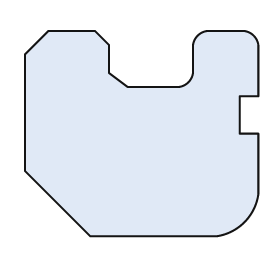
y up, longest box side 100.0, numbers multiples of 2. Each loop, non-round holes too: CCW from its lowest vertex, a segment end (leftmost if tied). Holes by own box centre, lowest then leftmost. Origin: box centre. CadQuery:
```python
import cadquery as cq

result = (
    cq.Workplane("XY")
    .moveTo(-22.0, -44.0)
    .lineTo(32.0, -44.0)
    .threePointArc((44.0, -38.0), (50.0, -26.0))
    .lineTo(50.0, 0.0)
    .lineTo(42.0, 0.0)
    .lineTo(42.0, 16.0)
    .lineTo(50.0, 16.0)
    .lineTo(50.0, 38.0)
    .threePointArc((48.0, 42.0), (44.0, 44.0))
    .lineTo(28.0, 44.0)
    .threePointArc((24.0, 42.0), (22.0, 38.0))
    .lineTo(22.0, 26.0)
    .threePointArc((20.0, 22.0), (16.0, 20.0))
    .lineTo(-6.0, 20.0)
    .lineTo(-14.0, 26.0)
    .lineTo(-14.0, 38.0)
    .lineTo(-20.0, 44.0)
    .lineTo(-40.0, 44.0)
    .lineTo(-50.0, 34.0)
    .lineTo(-50.0, -16.0)
    .close()
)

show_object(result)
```